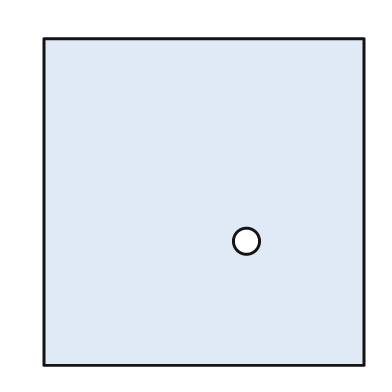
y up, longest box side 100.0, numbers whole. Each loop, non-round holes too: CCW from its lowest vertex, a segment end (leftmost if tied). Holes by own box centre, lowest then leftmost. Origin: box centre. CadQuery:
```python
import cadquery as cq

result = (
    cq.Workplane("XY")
    .moveTo(-49.0, -50.0)
    .lineTo(49.0, -50.0)
    .lineTo(49.0, 50.0)
    .lineTo(-49.0, 50.0)
    .close()
    .moveTo(13.0, -12.0)
    .circle(4.0)
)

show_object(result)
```